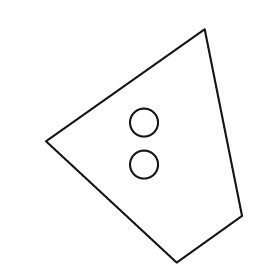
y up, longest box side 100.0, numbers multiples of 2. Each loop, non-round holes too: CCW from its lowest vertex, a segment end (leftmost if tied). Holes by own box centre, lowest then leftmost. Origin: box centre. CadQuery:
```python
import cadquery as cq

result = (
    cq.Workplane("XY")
    .moveTo(14.0, -50.0)
    .lineTo(42.0, -30.0)
    .lineTo(26.0, 50.0)
    .lineTo(-42.0, 2.0)
    .close()
    .moveTo(0.0, -8.0)
    .circle(6.0)
    .moveTo(0.0, 10.0)
    .circle(6.0)
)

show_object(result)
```